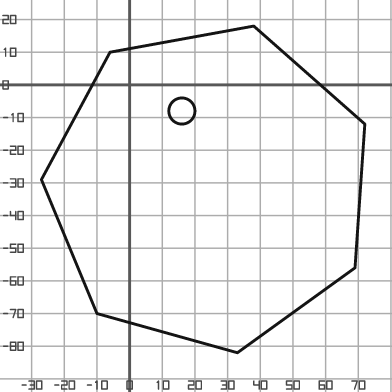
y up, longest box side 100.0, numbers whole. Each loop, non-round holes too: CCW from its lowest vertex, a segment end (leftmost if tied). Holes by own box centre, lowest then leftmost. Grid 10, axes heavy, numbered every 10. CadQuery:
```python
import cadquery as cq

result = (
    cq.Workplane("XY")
    .moveTo(33.0, -82.0)
    .lineTo(69.0, -56.0)
    .lineTo(72.0, -12.0)
    .lineTo(38.0, 18.0)
    .lineTo(-6.0, 10.0)
    .lineTo(-27.0, -29.0)
    .lineTo(-10.0, -70.0)
    .close()
    .moveTo(16.0, -8.0)
    .circle(4.0)
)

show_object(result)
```